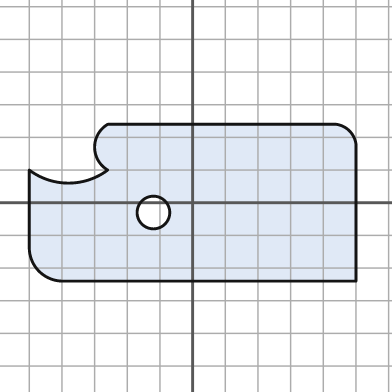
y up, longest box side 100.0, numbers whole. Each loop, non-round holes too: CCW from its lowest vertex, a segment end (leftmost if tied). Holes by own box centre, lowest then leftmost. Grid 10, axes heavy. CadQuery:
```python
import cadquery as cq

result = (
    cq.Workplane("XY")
    .moveTo(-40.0, -24.0)
    .lineTo(50.0, -24.0)
    .lineTo(50.0, 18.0)
    .threePointArc((48.0, 22.0), (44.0, 24.0))
    .lineTo(-26.0, 24.0)
    .threePointArc((-30.0, 17.0), (-26.0, 10.0))
    .threePointArc((-38.0, 6.0), (-50.0, 10.0))
    .lineTo(-50.0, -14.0)
    .threePointArc((-47.0, -21.0), (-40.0, -24.0))
    .close()
    .moveTo(-12.0, -3.0)
    .circle(5.0)
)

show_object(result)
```